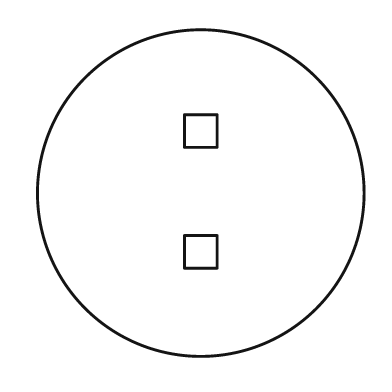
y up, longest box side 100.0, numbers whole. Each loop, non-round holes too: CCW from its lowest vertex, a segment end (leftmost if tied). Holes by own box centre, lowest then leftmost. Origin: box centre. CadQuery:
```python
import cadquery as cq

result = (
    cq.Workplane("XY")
    .moveTo(0.0, 0.0)
    .circle(50.0)
    .moveTo(-5.0, -23.0)
    .lineTo(5.0, -23.0)
    .lineTo(5.0, -13.0)
    .lineTo(-5.0, -13.0)
    .close()
    .moveTo(-5.0, 14.0)
    .lineTo(5.0, 14.0)
    .lineTo(5.0, 24.0)
    .lineTo(-5.0, 24.0)
    .close()
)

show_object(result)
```